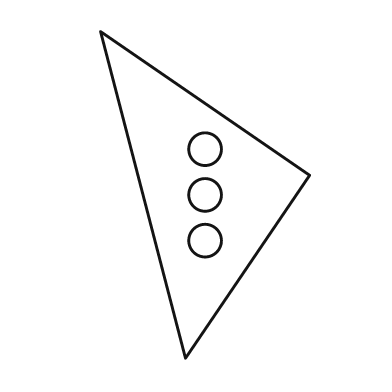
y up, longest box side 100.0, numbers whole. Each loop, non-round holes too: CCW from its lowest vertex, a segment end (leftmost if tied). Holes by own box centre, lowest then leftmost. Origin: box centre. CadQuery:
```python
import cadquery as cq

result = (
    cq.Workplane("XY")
    .moveTo(-6.0, -50.0)
    .lineTo(32.0, 6.0)
    .lineTo(-32.0, 50.0)
    .close()
    .moveTo(0.0, -14.0)
    .circle(5.0)
    .moveTo(0.0, 0.0)
    .circle(5.0)
    .moveTo(0.0, 14.0)
    .circle(5.0)
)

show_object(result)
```